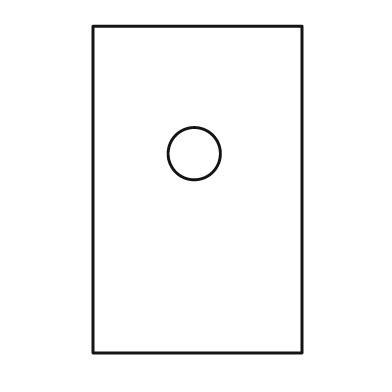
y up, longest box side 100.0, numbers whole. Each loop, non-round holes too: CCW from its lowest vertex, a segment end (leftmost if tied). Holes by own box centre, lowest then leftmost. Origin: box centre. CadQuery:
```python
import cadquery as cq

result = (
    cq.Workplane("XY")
    .moveTo(-32.0, -50.0)
    .lineTo(32.0, -50.0)
    .lineTo(32.0, 50.0)
    .lineTo(-32.0, 50.0)
    .close()
    .moveTo(-1.0, 11.0)
    .circle(8.0)
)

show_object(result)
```